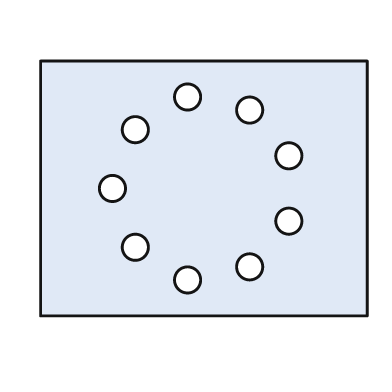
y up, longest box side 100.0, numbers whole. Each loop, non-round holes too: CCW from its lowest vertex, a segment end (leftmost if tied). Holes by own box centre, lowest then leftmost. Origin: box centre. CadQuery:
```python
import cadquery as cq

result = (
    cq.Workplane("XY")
    .moveTo(-50.0, -39.0)
    .lineTo(50.0, -39.0)
    .lineTo(50.0, 39.0)
    .lineTo(-50.0, 39.0)
    .close()
    .moveTo(-5.0, -28.0)
    .circle(4.0)
    .moveTo(14.0, -24.0)
    .circle(4.0)
    .moveTo(-21.0, -18.0)
    .circle(4.0)
    .moveTo(26.0, -10.0)
    .circle(4.0)
    .moveTo(-28.0, 0.0)
    .circle(4.0)
    .moveTo(26.0, 10.0)
    .circle(4.0)
    .moveTo(-21.0, 18.0)
    .circle(4.0)
    .moveTo(14.0, 24.0)
    .circle(4.0)
    .moveTo(-5.0, 28.0)
    .circle(4.0)
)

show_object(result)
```